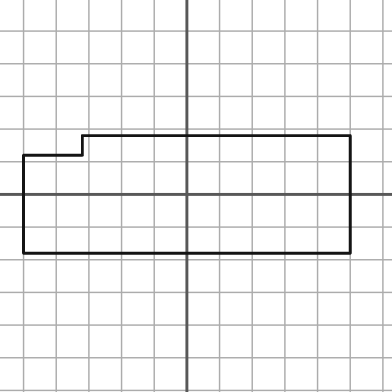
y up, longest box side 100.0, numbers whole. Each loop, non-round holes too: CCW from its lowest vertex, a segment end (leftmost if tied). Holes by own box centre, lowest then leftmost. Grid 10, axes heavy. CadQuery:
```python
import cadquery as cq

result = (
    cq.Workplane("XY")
    .moveTo(-50.0, -18.0)
    .lineTo(50.0, -18.0)
    .lineTo(50.0, 18.0)
    .lineTo(-32.0, 18.0)
    .lineTo(-32.0, 12.0)
    .lineTo(-50.0, 12.0)
    .close()
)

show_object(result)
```